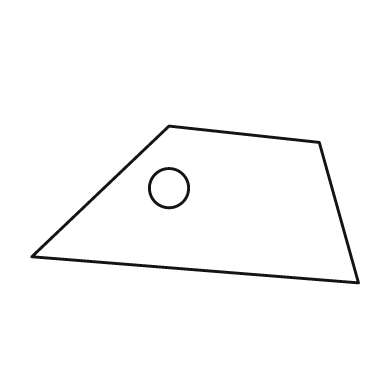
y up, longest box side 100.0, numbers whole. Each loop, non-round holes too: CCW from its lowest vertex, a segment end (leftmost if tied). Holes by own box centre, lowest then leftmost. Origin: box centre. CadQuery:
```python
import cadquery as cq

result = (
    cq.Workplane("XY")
    .moveTo(50.0, -24.0)
    .lineTo(38.0, 19.0)
    .lineTo(-8.0, 24.0)
    .lineTo(-50.0, -16.0)
    .close()
    .moveTo(-8.0, 5.0)
    .circle(6.0)
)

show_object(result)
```